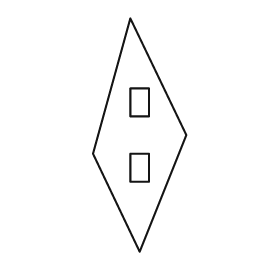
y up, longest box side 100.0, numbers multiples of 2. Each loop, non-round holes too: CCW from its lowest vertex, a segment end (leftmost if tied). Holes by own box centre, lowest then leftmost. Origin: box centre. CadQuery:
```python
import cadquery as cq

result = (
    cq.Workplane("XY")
    .moveTo(0.0, -50.0)
    .lineTo(20.0, 0.0)
    .lineTo(-4.0, 50.0)
    .lineTo(-20.0, -8.0)
    .close()
    .moveTo(-4.0, -20.0)
    .lineTo(4.0, -20.0)
    .lineTo(4.0, -8.0)
    .lineTo(-4.0, -8.0)
    .close()
    .moveTo(-4.0, 8.0)
    .lineTo(4.0, 8.0)
    .lineTo(4.0, 20.0)
    .lineTo(-4.0, 20.0)
    .close()
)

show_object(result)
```